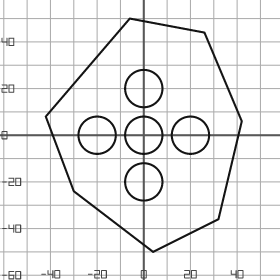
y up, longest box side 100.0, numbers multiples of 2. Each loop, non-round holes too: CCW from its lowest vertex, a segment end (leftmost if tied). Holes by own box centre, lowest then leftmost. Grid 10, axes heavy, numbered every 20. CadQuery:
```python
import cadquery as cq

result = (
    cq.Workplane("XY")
    .moveTo(4.0, -50.0)
    .lineTo(32.0, -36.0)
    .lineTo(42.0, 6.0)
    .lineTo(26.0, 44.0)
    .lineTo(-6.0, 50.0)
    .lineTo(-42.0, 8.0)
    .lineTo(-30.0, -24.0)
    .close()
    .moveTo(0.0, -20.0)
    .circle(8.0)
    .moveTo(-20.0, 0.0)
    .circle(8.0)
    .moveTo(0.0, 0.0)
    .circle(8.0)
    .moveTo(20.0, 0.0)
    .circle(8.0)
    .moveTo(0.0, 20.0)
    .circle(8.0)
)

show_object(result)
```